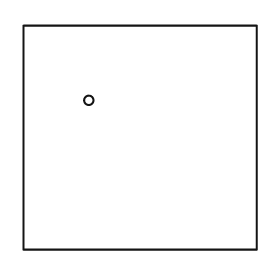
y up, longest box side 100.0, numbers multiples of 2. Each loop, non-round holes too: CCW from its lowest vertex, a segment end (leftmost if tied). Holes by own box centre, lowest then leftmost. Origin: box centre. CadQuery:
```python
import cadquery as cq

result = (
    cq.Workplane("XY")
    .moveTo(-50.0, -48.0)
    .lineTo(50.0, -48.0)
    .lineTo(50.0, 48.0)
    .lineTo(-50.0, 48.0)
    .close()
    .moveTo(-22.0, 16.0)
    .circle(2.0)
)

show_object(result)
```